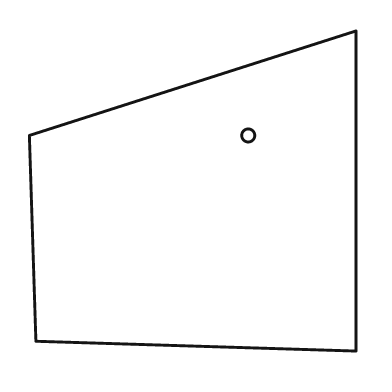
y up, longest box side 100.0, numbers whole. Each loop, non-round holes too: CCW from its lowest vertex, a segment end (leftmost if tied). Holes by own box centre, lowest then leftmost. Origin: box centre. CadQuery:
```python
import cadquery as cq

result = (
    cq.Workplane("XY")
    .moveTo(50.0, -49.0)
    .lineTo(50.0, 49.0)
    .lineTo(-50.0, 17.0)
    .lineTo(-48.0, -46.0)
    .close()
    .moveTo(17.0, 17.0)
    .circle(2.0)
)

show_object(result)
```